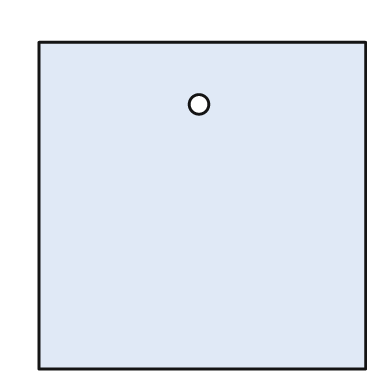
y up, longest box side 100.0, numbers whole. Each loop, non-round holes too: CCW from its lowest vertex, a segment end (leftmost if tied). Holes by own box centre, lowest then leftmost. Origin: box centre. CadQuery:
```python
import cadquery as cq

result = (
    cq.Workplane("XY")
    .moveTo(-50.0, -50.0)
    .lineTo(50.0, -50.0)
    .lineTo(50.0, 50.0)
    .lineTo(-50.0, 50.0)
    .close()
    .moveTo(-1.0, 31.0)
    .circle(3.0)
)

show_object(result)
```